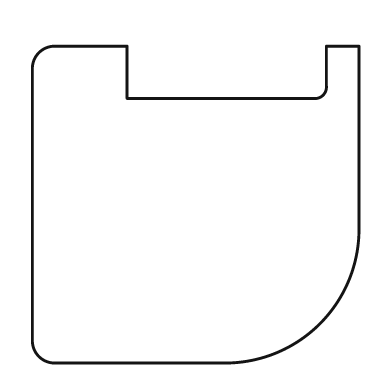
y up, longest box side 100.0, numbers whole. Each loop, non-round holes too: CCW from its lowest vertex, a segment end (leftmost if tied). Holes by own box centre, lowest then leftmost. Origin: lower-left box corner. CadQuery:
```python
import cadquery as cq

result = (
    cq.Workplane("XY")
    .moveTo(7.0, 0.0)
    .lineTo(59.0, 0.0)
    .threePointArc((88.0, 12.0), (100.0, 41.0))
    .lineTo(100.0, 97.0)
    .lineTo(90.0, 97.0)
    .lineTo(90.0, 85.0)
    .threePointArc((89.0, 82.0), (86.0, 81.0))
    .lineTo(29.0, 81.0)
    .lineTo(29.0, 97.0)
    .lineTo(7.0, 97.0)
    .threePointArc((2.0, 95.0), (0.0, 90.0))
    .lineTo(0.0, 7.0)
    .threePointArc((2.0, 2.0), (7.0, 0.0))
    .close()
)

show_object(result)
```